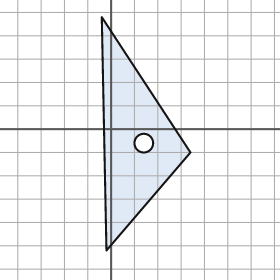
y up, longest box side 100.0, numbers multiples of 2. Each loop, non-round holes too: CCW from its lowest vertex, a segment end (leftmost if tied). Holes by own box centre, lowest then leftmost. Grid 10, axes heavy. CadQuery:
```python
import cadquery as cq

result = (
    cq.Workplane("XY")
    .moveTo(-2.0, -52.0)
    .lineTo(34.0, -10.0)
    .lineTo(-4.0, 48.0)
    .close()
    .moveTo(14.0, -6.0)
    .circle(4.0)
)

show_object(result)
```